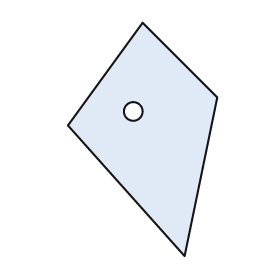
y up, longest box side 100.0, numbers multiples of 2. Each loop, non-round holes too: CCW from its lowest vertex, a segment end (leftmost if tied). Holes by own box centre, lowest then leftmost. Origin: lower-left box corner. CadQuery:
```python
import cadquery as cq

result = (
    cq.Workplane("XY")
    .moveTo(50.0, 0.0)
    .lineTo(64.0, 68.0)
    .lineTo(32.0, 100.0)
    .lineTo(0.0, 56.0)
    .close()
    .moveTo(28.0, 62.0)
    .circle(4.0)
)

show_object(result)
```